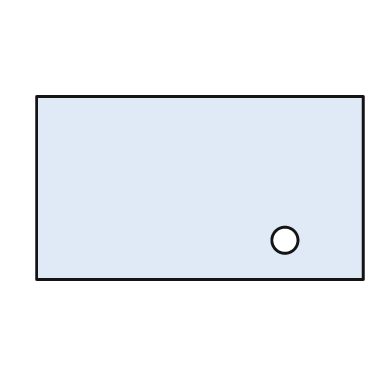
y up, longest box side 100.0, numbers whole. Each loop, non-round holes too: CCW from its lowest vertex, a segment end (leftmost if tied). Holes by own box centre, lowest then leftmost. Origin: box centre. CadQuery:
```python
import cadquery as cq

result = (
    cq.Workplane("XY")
    .moveTo(-50.0, -28.0)
    .lineTo(50.0, -28.0)
    .lineTo(50.0, 28.0)
    .lineTo(-50.0, 28.0)
    .close()
    .moveTo(26.0, -16.0)
    .circle(4.0)
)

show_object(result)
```